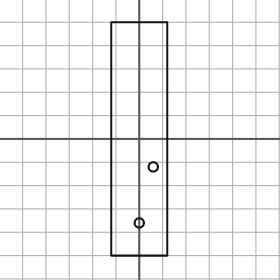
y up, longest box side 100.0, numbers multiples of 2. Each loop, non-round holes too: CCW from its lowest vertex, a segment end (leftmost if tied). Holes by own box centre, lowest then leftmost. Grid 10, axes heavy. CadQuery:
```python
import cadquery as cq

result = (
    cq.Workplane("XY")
    .moveTo(-12.0, -50.0)
    .lineTo(12.0, -50.0)
    .lineTo(12.0, 50.0)
    .lineTo(-12.0, 50.0)
    .close()
    .moveTo(0.0, -36.0)
    .circle(2.0)
    .moveTo(6.0, -12.0)
    .circle(2.0)
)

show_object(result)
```